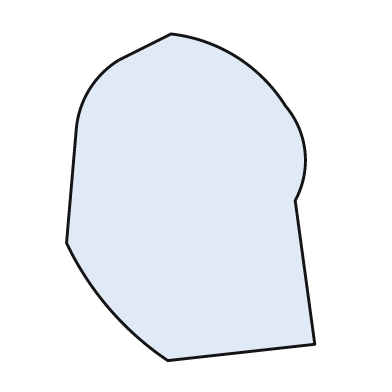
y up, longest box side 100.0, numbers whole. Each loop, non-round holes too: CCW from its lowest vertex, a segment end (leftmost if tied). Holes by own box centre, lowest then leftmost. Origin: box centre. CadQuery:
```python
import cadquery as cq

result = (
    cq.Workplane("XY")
    .moveTo(-7.0, -50.0)
    .lineTo(38.0, -45.0)
    .lineTo(32.0, -1.0)
    .threePointArc((35.0, 14.0), (29.0, 28.0))
    .threePointArc((14.0, 43.0), (-6.0, 50.0))
    .lineTo(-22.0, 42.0)
    .threePointArc((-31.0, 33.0), (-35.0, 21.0))
    .lineTo(-38.0, -14.0)
    .threePointArc((-25.0, -34.0), (-7.0, -50.0))
    .close()
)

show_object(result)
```